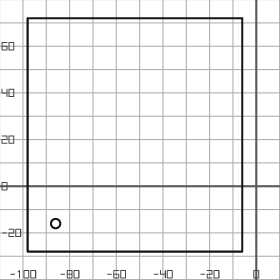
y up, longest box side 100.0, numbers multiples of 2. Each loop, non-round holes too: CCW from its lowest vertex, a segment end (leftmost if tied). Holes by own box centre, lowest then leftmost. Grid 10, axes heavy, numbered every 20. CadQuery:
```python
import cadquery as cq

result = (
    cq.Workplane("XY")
    .moveTo(-98.0, -28.0)
    .lineTo(-6.0, -28.0)
    .lineTo(-6.0, 72.0)
    .lineTo(-98.0, 72.0)
    .close()
    .moveTo(-86.0, -16.0)
    .circle(2.0)
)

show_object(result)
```